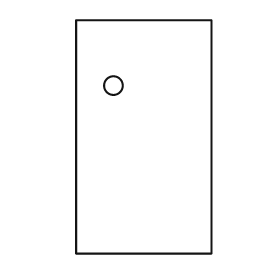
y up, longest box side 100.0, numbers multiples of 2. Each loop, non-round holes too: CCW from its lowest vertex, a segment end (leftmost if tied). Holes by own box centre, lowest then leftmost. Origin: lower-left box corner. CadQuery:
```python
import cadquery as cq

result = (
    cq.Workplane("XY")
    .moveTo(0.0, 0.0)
    .lineTo(58.0, 0.0)
    .lineTo(58.0, 100.0)
    .lineTo(0.0, 100.0)
    .close()
    .moveTo(16.0, 72.0)
    .circle(4.0)
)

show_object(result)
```